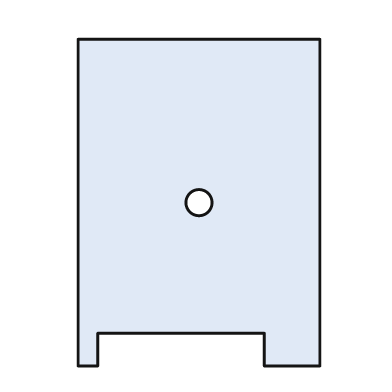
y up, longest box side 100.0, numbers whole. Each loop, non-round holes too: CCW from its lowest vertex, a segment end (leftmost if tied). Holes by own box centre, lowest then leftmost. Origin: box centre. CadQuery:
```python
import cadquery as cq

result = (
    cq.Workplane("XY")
    .moveTo(-37.0, -50.0)
    .lineTo(-31.0, -50.0)
    .lineTo(-31.0, -40.0)
    .lineTo(20.0, -40.0)
    .lineTo(20.0, -50.0)
    .lineTo(37.0, -50.0)
    .lineTo(37.0, 50.0)
    .lineTo(-37.0, 50.0)
    .close()
    .moveTo(0.0, 0.0)
    .circle(4.0)
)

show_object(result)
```